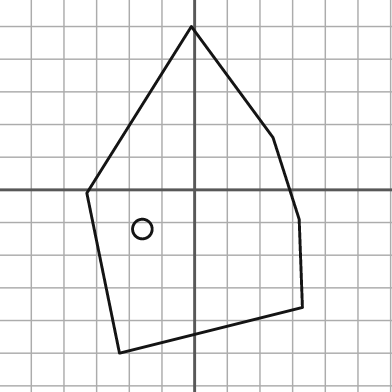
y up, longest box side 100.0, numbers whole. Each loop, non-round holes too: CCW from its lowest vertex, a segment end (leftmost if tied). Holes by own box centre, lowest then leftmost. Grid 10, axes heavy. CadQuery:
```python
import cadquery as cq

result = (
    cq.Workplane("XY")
    .moveTo(-23.0, -50.0)
    .lineTo(33.0, -36.0)
    .lineTo(32.0, -9.0)
    .lineTo(24.0, 16.0)
    .lineTo(-1.0, 50.0)
    .lineTo(-33.0, -1.0)
    .close()
    .moveTo(-16.0, -12.0)
    .circle(3.0)
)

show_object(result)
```